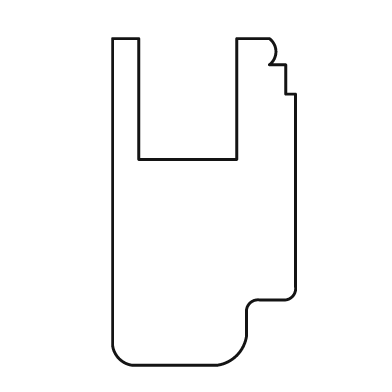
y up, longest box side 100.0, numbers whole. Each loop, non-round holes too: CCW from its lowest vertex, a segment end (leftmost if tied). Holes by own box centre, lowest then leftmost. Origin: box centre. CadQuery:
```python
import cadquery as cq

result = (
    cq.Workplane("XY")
    .moveTo(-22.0, -50.0)
    .lineTo(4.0, -50.0)
    .threePointArc((10.0, -47.0), (13.0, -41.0))
    .lineTo(13.0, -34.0)
    .threePointArc((14.0, -31.0), (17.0, -30.0))
    .lineTo(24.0, -30.0)
    .threePointArc((27.0, -29.0), (28.0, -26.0))
    .lineTo(28.0, 33.0)
    .lineTo(25.0, 33.0)
    .lineTo(25.0, 42.0)
    .lineTo(20.0, 42.0)
    .threePointArc((22.0, 46.0), (20.0, 50.0))
    .lineTo(10.0, 50.0)
    .lineTo(10.0, 13.0)
    .lineTo(-20.0, 13.0)
    .lineTo(-20.0, 50.0)
    .lineTo(-28.0, 50.0)
    .lineTo(-28.0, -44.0)
    .threePointArc((-26.0, -48.0), (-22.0, -50.0))
    .close()
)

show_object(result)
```